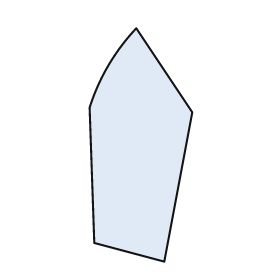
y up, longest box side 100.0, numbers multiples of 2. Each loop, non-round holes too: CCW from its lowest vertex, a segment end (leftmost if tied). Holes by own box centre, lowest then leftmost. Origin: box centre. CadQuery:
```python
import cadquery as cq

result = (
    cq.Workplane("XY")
    .moveTo(10.0, -50.0)
    .lineTo(22.0, 14.0)
    .lineTo(-2.0, 50.0)
    .threePointArc((-14.0, 34.0), (-22.0, 16.0))
    .lineTo(-20.0, -42.0)
    .close()
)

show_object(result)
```